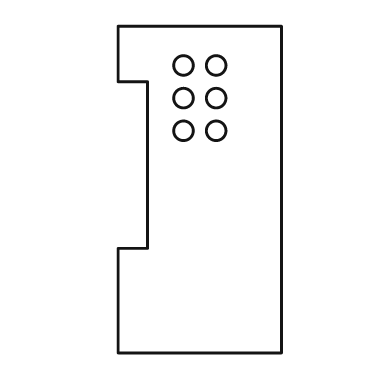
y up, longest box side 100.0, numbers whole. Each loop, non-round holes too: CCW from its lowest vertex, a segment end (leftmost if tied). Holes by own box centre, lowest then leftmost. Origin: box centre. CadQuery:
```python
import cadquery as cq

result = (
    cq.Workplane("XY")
    .moveTo(-25.0, -50.0)
    .lineTo(25.0, -50.0)
    .lineTo(25.0, 50.0)
    .lineTo(-25.0, 50.0)
    .lineTo(-25.0, 33.0)
    .lineTo(-16.0, 33.0)
    .lineTo(-16.0, -18.0)
    .lineTo(-25.0, -18.0)
    .close()
    .moveTo(-5.0, 18.0)
    .circle(3.0)
    .moveTo(5.0, 18.0)
    .circle(3.0)
    .moveTo(-5.0, 28.0)
    .circle(3.0)
    .moveTo(5.0, 28.0)
    .circle(3.0)
    .moveTo(-5.0, 38.0)
    .circle(3.0)
    .moveTo(5.0, 38.0)
    .circle(3.0)
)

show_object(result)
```